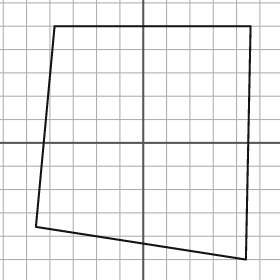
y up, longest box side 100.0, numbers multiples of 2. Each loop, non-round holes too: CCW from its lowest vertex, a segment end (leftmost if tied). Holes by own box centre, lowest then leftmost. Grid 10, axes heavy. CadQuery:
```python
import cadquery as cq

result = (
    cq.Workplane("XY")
    .moveTo(44.0, -50.0)
    .lineTo(46.0, 50.0)
    .lineTo(-38.0, 50.0)
    .lineTo(-46.0, -36.0)
    .close()
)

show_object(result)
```